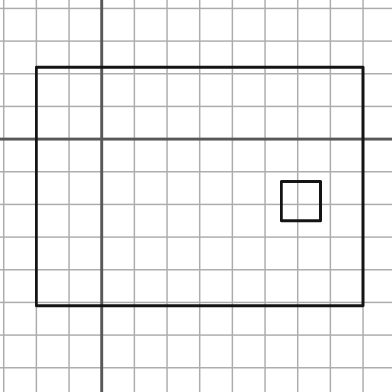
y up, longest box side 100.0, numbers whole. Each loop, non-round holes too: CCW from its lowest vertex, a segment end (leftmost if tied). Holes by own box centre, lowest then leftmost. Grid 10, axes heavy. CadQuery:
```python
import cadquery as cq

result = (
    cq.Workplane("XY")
    .moveTo(-20.0, -51.0)
    .lineTo(80.0, -51.0)
    .lineTo(80.0, 22.0)
    .lineTo(-20.0, 22.0)
    .close()
    .moveTo(55.0, -25.0)
    .lineTo(67.0, -25.0)
    .lineTo(67.0, -13.0)
    .lineTo(55.0, -13.0)
    .close()
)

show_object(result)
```